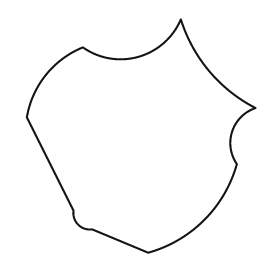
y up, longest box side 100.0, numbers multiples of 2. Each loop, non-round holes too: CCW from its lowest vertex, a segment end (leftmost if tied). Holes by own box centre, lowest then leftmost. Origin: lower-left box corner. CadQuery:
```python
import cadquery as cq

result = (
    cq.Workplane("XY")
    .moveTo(52.0, 0.0)
    .threePointArc((76.0, 14.0), (90.0, 38.0))
    .threePointArc((88.0, 52.0), (98.0, 62.0))
    .threePointArc((78.0, 78.0), (66.0, 100.0))
    .threePointArc((48.0, 84.0), (24.0, 88.0))
    .threePointArc((8.0, 76.0), (0.0, 58.0))
    .lineTo(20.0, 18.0)
    .threePointArc((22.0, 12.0), (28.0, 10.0))
    .close()
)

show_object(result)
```